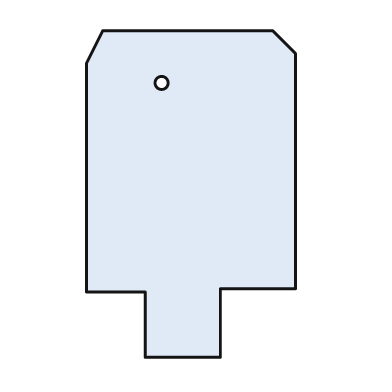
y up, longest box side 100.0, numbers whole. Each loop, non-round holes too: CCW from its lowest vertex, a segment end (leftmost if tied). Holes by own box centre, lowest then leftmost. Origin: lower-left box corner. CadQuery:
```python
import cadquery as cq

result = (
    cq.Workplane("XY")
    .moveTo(18.0, 0.0)
    .lineTo(41.0, 0.0)
    .lineTo(41.0, 21.0)
    .lineTo(64.0, 21.0)
    .lineTo(64.0, 93.0)
    .lineTo(57.0, 100.0)
    .lineTo(5.0, 100.0)
    .lineTo(0.0, 90.0)
    .lineTo(0.0, 20.0)
    .lineTo(18.0, 20.0)
    .close()
    .moveTo(23.0, 84.0)
    .circle(2.0)
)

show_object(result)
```